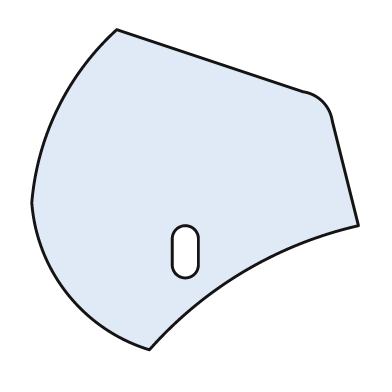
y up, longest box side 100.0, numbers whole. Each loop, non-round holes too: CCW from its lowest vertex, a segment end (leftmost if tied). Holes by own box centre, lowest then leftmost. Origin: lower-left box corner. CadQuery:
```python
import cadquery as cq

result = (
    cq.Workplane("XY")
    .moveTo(36.0, 0.0)
    .threePointArc((65.0, 24.0), (100.0, 38.0))
    .lineTo(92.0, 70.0)
    .threePointArc((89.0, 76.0), (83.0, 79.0))
    .lineTo(26.0, 98.0)
    .threePointArc((8.0, 74.0), (0.0, 45.0))
    .threePointArc((11.0, 17.0), (36.0, 0.0))
    .close()
    .moveTo(43.0, 26.0)
    .threePointArc((47.0, 22.0), (51.0, 26.0))
    .lineTo(51.0, 34.0)
    .threePointArc((47.0, 38.0), (43.0, 34.0))
    .close()
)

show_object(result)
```